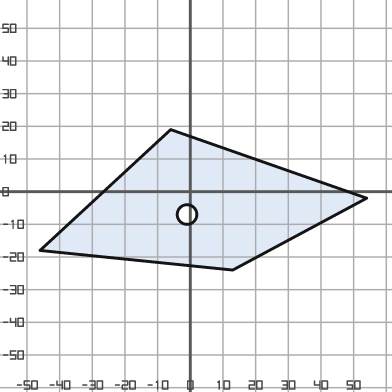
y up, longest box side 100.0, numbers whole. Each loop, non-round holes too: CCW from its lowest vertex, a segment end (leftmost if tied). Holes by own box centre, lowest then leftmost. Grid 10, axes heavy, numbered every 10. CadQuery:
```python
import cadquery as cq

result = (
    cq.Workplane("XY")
    .moveTo(13.0, -24.0)
    .lineTo(54.0, -2.0)
    .lineTo(-6.0, 19.0)
    .lineTo(-46.0, -18.0)
    .close()
    .moveTo(-1.0, -7.0)
    .circle(3.0)
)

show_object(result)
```